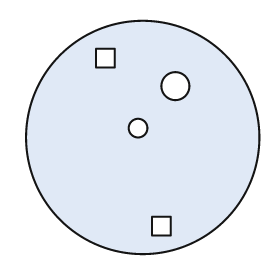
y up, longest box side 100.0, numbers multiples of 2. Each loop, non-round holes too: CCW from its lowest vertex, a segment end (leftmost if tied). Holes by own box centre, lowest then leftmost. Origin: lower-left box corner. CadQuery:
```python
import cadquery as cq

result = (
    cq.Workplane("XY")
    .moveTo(50.0, 50.0)
    .circle(50.0)
    .moveTo(54.0, 8.0)
    .lineTo(62.0, 8.0)
    .lineTo(62.0, 16.0)
    .lineTo(54.0, 16.0)
    .close()
    .moveTo(48.0, 54.0)
    .circle(4.0)
    .moveTo(64.0, 72.0)
    .circle(6.0)
    .moveTo(30.0, 80.0)
    .lineTo(38.0, 80.0)
    .lineTo(38.0, 88.0)
    .lineTo(30.0, 88.0)
    .close()
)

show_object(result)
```